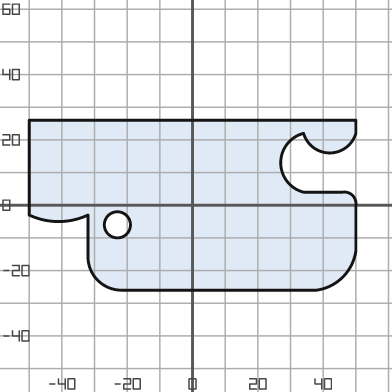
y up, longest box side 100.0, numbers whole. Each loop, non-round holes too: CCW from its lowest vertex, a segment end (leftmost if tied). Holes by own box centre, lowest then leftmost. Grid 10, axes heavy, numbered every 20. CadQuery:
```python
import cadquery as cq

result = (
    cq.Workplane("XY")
    .moveTo(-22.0, -26.0)
    .lineTo(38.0, -26.0)
    .threePointArc((46.0, -22.0), (50.0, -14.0))
    .lineTo(50.0, 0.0)
    .threePointArc((49.0, 3.0), (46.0, 4.0))
    .lineTo(34.0, 4.0)
    .threePointArc((27.0, 13.0), (34.0, 22.0))
    .threePointArc((42.0, 16.0), (50.0, 22.0))
    .lineTo(50.0, 26.0)
    .lineTo(-50.0, 26.0)
    .lineTo(-50.0, -3.0)
    .threePointArc((-41.0, -5.0), (-32.0, -3.0))
    .lineTo(-32.0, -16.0)
    .threePointArc((-29.0, -23.0), (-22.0, -26.0))
    .close()
    .moveTo(-23.0, -6.0)
    .circle(4.0)
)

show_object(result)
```